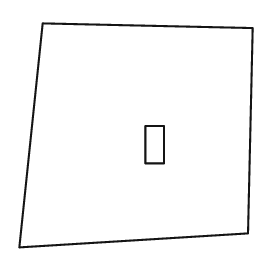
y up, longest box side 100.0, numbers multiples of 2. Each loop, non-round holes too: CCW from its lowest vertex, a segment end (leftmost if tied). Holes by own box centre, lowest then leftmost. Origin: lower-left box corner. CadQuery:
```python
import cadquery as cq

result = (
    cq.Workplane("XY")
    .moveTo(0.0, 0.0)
    .lineTo(98.0, 6.0)
    .lineTo(100.0, 94.0)
    .lineTo(10.0, 96.0)
    .close()
    .moveTo(54.0, 36.0)
    .lineTo(62.0, 36.0)
    .lineTo(62.0, 52.0)
    .lineTo(54.0, 52.0)
    .close()
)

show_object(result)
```